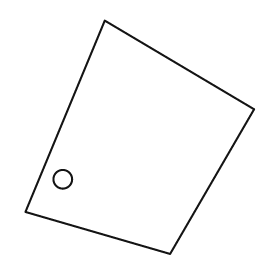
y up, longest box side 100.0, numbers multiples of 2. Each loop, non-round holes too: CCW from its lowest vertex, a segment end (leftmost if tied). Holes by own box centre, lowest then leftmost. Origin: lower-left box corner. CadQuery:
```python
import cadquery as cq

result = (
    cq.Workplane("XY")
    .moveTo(62.0, 0.0)
    .lineTo(98.0, 62.0)
    .lineTo(34.0, 100.0)
    .lineTo(0.0, 18.0)
    .close()
    .moveTo(16.0, 32.0)
    .circle(4.0)
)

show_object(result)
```